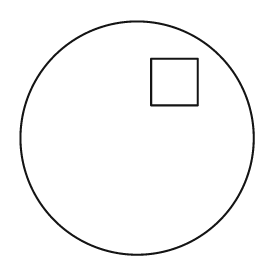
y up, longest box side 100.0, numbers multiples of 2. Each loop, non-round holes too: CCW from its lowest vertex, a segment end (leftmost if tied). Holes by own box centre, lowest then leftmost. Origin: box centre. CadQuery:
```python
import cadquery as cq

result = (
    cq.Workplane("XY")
    .moveTo(0.0, 0.0)
    .circle(50.0)
    .moveTo(6.0, 14.0)
    .lineTo(26.0, 14.0)
    .lineTo(26.0, 34.0)
    .lineTo(6.0, 34.0)
    .close()
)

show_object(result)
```